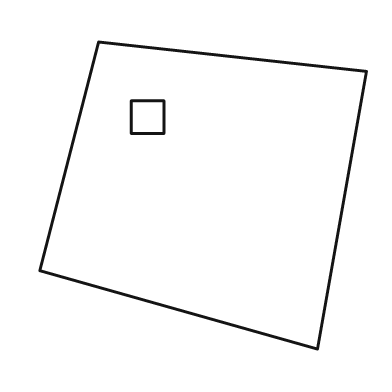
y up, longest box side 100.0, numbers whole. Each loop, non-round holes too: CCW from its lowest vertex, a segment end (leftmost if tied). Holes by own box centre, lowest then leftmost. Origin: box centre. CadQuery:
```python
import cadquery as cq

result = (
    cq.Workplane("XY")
    .moveTo(35.0, -47.0)
    .lineTo(50.0, 38.0)
    .lineTo(-32.0, 47.0)
    .lineTo(-50.0, -23.0)
    .close()
    .moveTo(-22.0, 19.0)
    .lineTo(-12.0, 19.0)
    .lineTo(-12.0, 29.0)
    .lineTo(-22.0, 29.0)
    .close()
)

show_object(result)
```